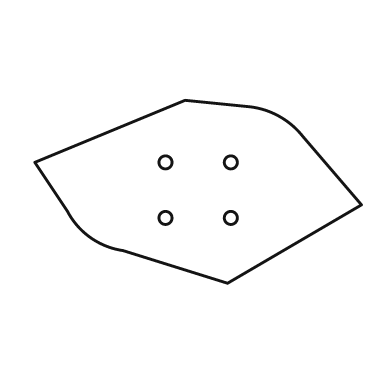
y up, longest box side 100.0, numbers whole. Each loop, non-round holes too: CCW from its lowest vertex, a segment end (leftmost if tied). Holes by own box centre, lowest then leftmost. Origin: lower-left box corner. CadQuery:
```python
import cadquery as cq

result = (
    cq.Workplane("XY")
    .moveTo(59.0, 0.0)
    .lineTo(100.0, 24.0)
    .lineTo(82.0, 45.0)
    .threePointArc((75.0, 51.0), (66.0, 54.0))
    .lineTo(46.0, 56.0)
    .lineTo(0.0, 37.0)
    .lineTo(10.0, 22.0)
    .threePointArc((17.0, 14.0), (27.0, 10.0))
    .close()
    .moveTo(40.0, 20.0)
    .circle(2.0)
    .moveTo(60.0, 20.0)
    .circle(2.0)
    .moveTo(40.0, 37.0)
    .circle(2.0)
    .moveTo(60.0, 37.0)
    .circle(2.0)
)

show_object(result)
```